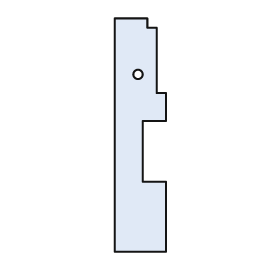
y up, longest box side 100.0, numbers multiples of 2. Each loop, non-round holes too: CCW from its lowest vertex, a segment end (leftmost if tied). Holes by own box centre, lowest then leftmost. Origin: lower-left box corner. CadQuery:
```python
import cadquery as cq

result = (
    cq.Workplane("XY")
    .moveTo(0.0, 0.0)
    .lineTo(22.0, 0.0)
    .lineTo(22.0, 30.0)
    .lineTo(12.0, 30.0)
    .lineTo(12.0, 56.0)
    .lineTo(22.0, 56.0)
    .lineTo(22.0, 68.0)
    .lineTo(18.0, 68.0)
    .lineTo(18.0, 96.0)
    .lineTo(14.0, 96.0)
    .lineTo(14.0, 100.0)
    .lineTo(0.0, 100.0)
    .close()
    .moveTo(10.0, 76.0)
    .circle(2.0)
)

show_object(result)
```